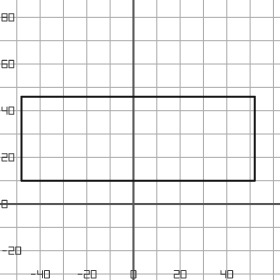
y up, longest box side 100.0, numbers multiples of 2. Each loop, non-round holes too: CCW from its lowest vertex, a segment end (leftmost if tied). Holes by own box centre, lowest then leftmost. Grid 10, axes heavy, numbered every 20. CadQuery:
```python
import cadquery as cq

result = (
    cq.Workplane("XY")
    .moveTo(-48.0, 10.0)
    .lineTo(52.0, 10.0)
    .lineTo(52.0, 46.0)
    .lineTo(-48.0, 46.0)
    .close()
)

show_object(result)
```